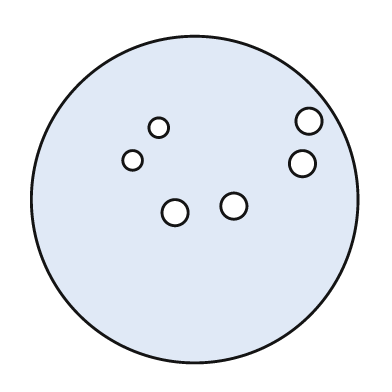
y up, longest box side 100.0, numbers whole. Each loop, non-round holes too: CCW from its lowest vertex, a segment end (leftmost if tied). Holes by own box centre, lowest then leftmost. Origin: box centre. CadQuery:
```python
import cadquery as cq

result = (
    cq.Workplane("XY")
    .moveTo(0.0, 0.0)
    .circle(50.0)
    .moveTo(-6.0, -4.0)
    .circle(4.0)
    .moveTo(12.0, -2.0)
    .circle(4.0)
    .moveTo(33.0, 11.0)
    .circle(4.0)
    .moveTo(-19.0, 12.0)
    .circle(3.0)
    .moveTo(-11.0, 22.0)
    .circle(3.0)
    .moveTo(35.0, 24.0)
    .circle(4.0)
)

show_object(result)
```